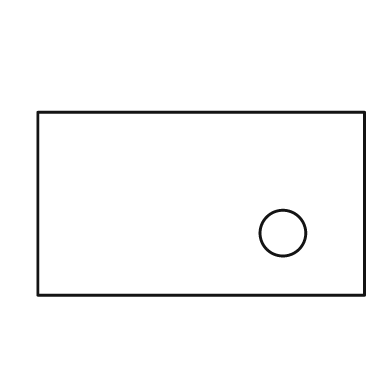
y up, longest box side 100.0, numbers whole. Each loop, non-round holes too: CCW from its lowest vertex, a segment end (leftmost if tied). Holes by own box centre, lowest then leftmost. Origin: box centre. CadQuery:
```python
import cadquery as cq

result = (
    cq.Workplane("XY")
    .moveTo(-50.0, -28.0)
    .lineTo(50.0, -28.0)
    .lineTo(50.0, 28.0)
    .lineTo(-50.0, 28.0)
    .close()
    .moveTo(25.0, -9.0)
    .circle(7.0)
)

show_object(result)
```